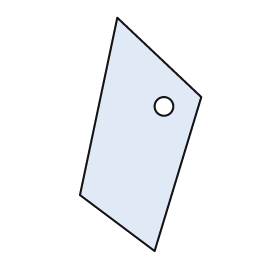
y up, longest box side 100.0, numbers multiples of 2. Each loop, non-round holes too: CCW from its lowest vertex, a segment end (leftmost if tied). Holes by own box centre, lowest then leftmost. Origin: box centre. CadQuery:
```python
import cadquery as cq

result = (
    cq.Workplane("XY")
    .moveTo(6.0, -50.0)
    .lineTo(26.0, 16.0)
    .lineTo(-10.0, 50.0)
    .lineTo(-26.0, -26.0)
    .close()
    .moveTo(10.0, 12.0)
    .circle(4.0)
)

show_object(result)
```